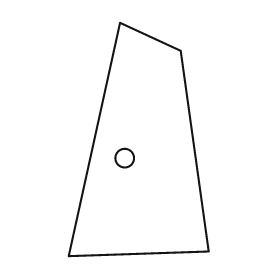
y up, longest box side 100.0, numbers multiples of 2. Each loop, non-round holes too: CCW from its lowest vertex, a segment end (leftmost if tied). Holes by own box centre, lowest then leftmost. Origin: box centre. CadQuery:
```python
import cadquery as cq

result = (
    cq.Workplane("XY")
    .moveTo(-30.0, -50.0)
    .lineTo(30.0, -48.0)
    .lineTo(18.0, 38.0)
    .lineTo(-8.0, 50.0)
    .close()
    .moveTo(-6.0, -8.0)
    .circle(4.0)
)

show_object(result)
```